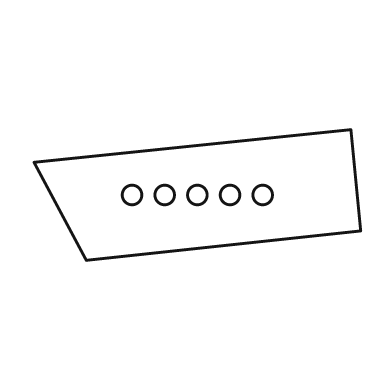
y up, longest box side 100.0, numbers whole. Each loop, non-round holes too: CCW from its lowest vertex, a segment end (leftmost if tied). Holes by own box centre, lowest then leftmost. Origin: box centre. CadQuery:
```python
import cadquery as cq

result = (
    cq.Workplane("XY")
    .moveTo(-34.0, -20.0)
    .lineTo(50.0, -11.0)
    .lineTo(47.0, 20.0)
    .lineTo(-50.0, 10.0)
    .close()
    .moveTo(-20.0, 0.0)
    .circle(3.0)
    .moveTo(-10.0, 0.0)
    .circle(3.0)
    .moveTo(0.0, 0.0)
    .circle(3.0)
    .moveTo(10.0, 0.0)
    .circle(3.0)
    .moveTo(20.0, 0.0)
    .circle(3.0)
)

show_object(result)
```